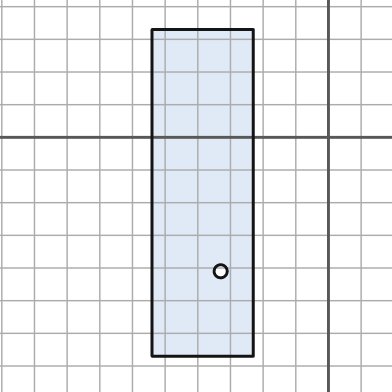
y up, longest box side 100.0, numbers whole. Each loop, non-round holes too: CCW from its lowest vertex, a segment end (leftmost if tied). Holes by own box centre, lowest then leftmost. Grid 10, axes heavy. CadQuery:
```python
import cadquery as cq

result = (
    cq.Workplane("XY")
    .moveTo(-54.0, -67.0)
    .lineTo(-23.0, -67.0)
    .lineTo(-23.0, 33.0)
    .lineTo(-54.0, 33.0)
    .close()
    .moveTo(-33.0, -41.0)
    .circle(2.0)
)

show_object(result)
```